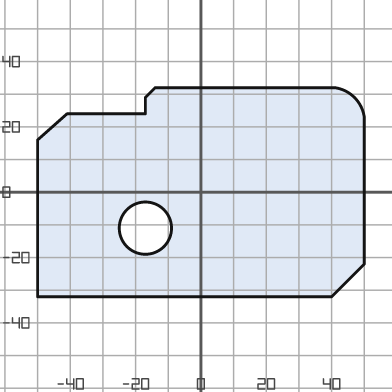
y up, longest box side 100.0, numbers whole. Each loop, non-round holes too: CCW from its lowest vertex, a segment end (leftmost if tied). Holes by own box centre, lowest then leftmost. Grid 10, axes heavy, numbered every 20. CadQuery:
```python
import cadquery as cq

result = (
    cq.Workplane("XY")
    .moveTo(-50.0, -32.0)
    .lineTo(40.0, -32.0)
    .lineTo(50.0, -22.0)
    .lineTo(50.0, 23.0)
    .threePointArc((47.0, 29.0), (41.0, 32.0))
    .lineTo(-14.0, 32.0)
    .lineTo(-17.0, 29.0)
    .lineTo(-17.0, 24.0)
    .lineTo(-41.0, 24.0)
    .lineTo(-50.0, 16.0)
    .close()
    .moveTo(-17.0, -11.0)
    .circle(8.0)
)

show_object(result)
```